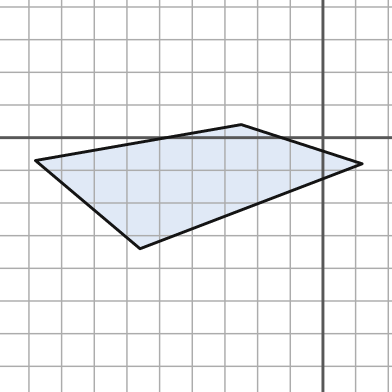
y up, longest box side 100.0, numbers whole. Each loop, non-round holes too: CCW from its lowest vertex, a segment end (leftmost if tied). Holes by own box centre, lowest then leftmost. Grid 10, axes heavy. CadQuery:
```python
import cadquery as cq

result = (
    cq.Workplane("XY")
    .moveTo(-56.0, -34.0)
    .lineTo(12.0, -8.0)
    .lineTo(-25.0, 4.0)
    .lineTo(-88.0, -7.0)
    .close()
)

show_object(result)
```